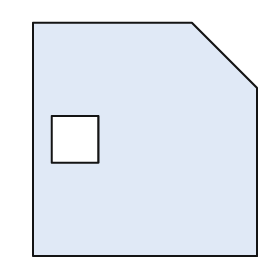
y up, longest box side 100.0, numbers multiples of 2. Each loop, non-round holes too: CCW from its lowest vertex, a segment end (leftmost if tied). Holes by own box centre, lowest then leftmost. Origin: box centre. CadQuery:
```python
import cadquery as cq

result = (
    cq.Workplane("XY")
    .moveTo(-48.0, -50.0)
    .lineTo(48.0, -50.0)
    .lineTo(48.0, 22.0)
    .lineTo(20.0, 50.0)
    .lineTo(-48.0, 50.0)
    .close()
    .moveTo(-40.0, -10.0)
    .lineTo(-20.0, -10.0)
    .lineTo(-20.0, 10.0)
    .lineTo(-40.0, 10.0)
    .close()
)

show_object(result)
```